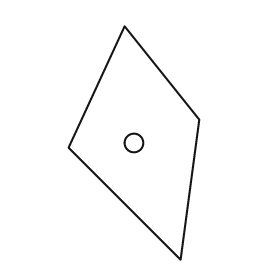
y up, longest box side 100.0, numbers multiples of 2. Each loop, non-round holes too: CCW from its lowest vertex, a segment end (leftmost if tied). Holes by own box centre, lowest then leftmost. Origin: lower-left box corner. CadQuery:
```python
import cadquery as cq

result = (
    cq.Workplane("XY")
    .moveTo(48.0, 0.0)
    .lineTo(56.0, 60.0)
    .lineTo(24.0, 100.0)
    .lineTo(0.0, 48.0)
    .close()
    .moveTo(28.0, 50.0)
    .circle(4.0)
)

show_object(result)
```